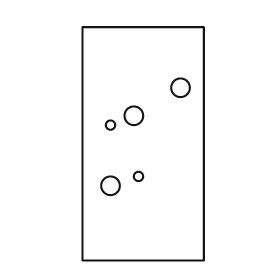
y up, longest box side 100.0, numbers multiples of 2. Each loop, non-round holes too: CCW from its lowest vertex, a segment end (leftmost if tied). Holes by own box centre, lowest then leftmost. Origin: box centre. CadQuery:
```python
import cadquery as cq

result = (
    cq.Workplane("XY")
    .moveTo(-26.0, -50.0)
    .lineTo(26.0, -50.0)
    .lineTo(26.0, 50.0)
    .lineTo(-26.0, 50.0)
    .close()
    .moveTo(-14.0, -18.0)
    .circle(4.0)
    .moveTo(-2.0, -14.0)
    .circle(2.0)
    .moveTo(-14.0, 8.0)
    .circle(2.0)
    .moveTo(-4.0, 12.0)
    .circle(4.0)
    .moveTo(16.0, 24.0)
    .circle(4.0)
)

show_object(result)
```